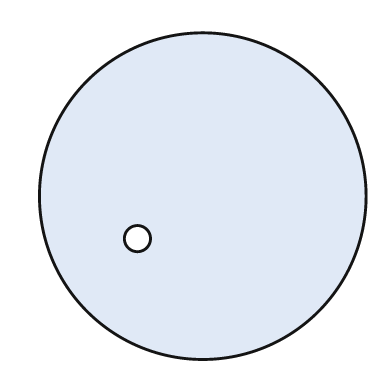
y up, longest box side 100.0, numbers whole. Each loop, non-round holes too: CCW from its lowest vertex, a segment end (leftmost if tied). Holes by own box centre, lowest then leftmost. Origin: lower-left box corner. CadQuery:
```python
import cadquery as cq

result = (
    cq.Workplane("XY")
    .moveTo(50.0, 50.0)
    .circle(50.0)
    .moveTo(30.0, 37.0)
    .circle(4.0)
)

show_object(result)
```